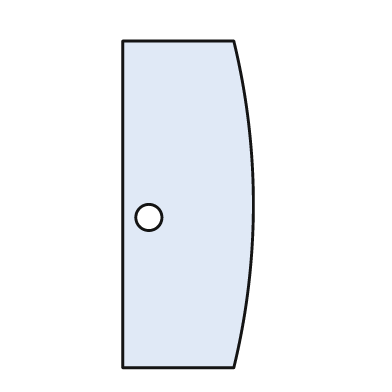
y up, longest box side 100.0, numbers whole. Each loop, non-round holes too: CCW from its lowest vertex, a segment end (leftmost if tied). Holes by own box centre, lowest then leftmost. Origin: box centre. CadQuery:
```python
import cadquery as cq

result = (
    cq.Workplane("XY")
    .moveTo(-20.0, -50.0)
    .lineTo(14.0, -50.0)
    .threePointArc((20.0, 0.0), (14.0, 50.0))
    .lineTo(-20.0, 50.0)
    .close()
    .moveTo(-12.0, -4.0)
    .circle(4.0)
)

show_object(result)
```